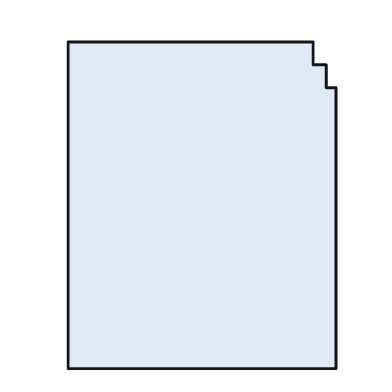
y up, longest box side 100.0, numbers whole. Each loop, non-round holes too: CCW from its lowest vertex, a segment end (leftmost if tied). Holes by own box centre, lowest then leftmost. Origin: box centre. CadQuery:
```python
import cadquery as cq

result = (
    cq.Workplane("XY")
    .moveTo(-41.0, -50.0)
    .lineTo(41.0, -50.0)
    .lineTo(41.0, 36.0)
    .lineTo(38.0, 36.0)
    .lineTo(38.0, 43.0)
    .lineTo(34.0, 43.0)
    .lineTo(34.0, 50.0)
    .lineTo(-41.0, 50.0)
    .close()
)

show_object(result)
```